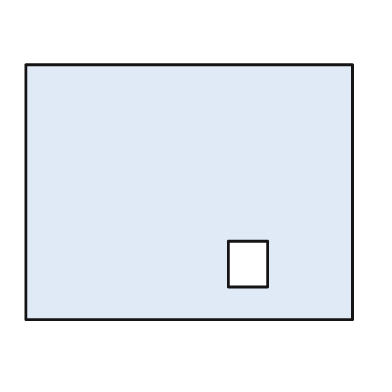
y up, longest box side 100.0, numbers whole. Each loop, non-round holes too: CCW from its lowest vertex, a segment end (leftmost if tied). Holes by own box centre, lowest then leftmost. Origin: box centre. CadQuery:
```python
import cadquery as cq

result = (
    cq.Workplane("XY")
    .moveTo(-50.0, -39.0)
    .lineTo(50.0, -39.0)
    .lineTo(50.0, 39.0)
    .lineTo(-50.0, 39.0)
    .close()
    .moveTo(12.0, -29.0)
    .lineTo(24.0, -29.0)
    .lineTo(24.0, -15.0)
    .lineTo(12.0, -15.0)
    .close()
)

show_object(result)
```